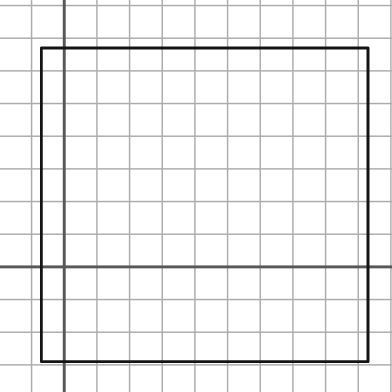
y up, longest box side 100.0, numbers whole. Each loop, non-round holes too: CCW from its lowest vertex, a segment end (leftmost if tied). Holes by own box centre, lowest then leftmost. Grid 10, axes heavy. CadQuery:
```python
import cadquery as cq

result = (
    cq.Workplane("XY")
    .moveTo(-7.0, -29.0)
    .lineTo(93.0, -29.0)
    .lineTo(93.0, 67.0)
    .lineTo(-7.0, 67.0)
    .close()
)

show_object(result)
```